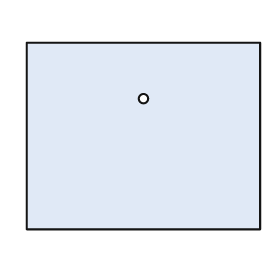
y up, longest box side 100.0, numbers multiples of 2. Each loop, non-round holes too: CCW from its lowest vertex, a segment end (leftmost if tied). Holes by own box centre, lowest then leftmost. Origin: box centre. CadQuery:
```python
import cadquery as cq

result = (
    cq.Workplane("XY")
    .moveTo(-50.0, -40.0)
    .lineTo(50.0, -40.0)
    .lineTo(50.0, 40.0)
    .lineTo(-50.0, 40.0)
    .close()
    .moveTo(0.0, 16.0)
    .circle(2.0)
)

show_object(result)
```